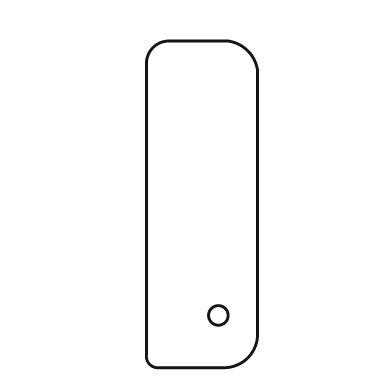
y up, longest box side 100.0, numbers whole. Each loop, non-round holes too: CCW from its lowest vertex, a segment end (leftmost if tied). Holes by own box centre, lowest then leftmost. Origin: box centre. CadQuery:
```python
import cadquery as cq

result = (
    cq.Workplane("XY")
    .moveTo(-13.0, -50.0)
    .lineTo(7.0, -50.0)
    .threePointArc((14.0, -47.0), (17.0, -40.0))
    .lineTo(17.0, 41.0)
    .threePointArc((14.0, 47.0), (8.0, 50.0))
    .lineTo(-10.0, 50.0)
    .threePointArc((-15.0, 48.0), (-17.0, 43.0))
    .lineTo(-17.0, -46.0)
    .threePointArc((-16.0, -49.0), (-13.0, -50.0))
    .close()
    .moveTo(5.0, -34.0)
    .circle(3.0)
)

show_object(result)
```